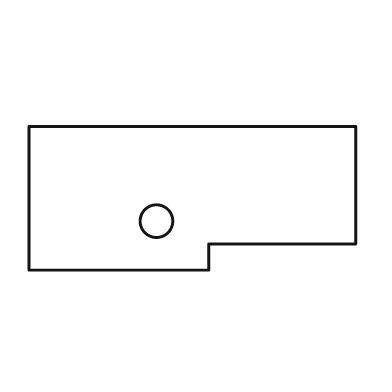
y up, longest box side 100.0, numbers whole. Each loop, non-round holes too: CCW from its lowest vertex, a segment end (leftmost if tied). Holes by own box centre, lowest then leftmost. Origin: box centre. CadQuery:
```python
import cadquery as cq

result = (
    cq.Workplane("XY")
    .moveTo(-50.0, -22.0)
    .lineTo(5.0, -22.0)
    .lineTo(5.0, -14.0)
    .lineTo(50.0, -14.0)
    .lineTo(50.0, 22.0)
    .lineTo(-50.0, 22.0)
    .close()
    .moveTo(-11.0, -7.0)
    .circle(5.0)
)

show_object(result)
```